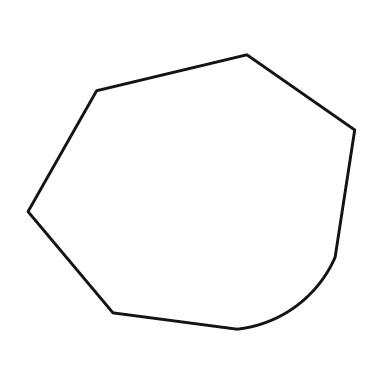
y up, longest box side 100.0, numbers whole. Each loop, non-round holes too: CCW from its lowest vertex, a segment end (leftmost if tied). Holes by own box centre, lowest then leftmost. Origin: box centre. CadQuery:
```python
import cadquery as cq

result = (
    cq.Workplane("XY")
    .moveTo(14.0, -42.0)
    .threePointArc((32.0, -35.0), (44.0, -20.0))
    .lineTo(50.0, 19.0)
    .lineTo(17.0, 42.0)
    .lineTo(-29.0, 31.0)
    .lineTo(-50.0, -6.0)
    .lineTo(-24.0, -37.0)
    .close()
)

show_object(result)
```